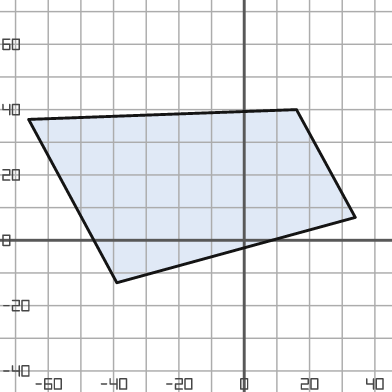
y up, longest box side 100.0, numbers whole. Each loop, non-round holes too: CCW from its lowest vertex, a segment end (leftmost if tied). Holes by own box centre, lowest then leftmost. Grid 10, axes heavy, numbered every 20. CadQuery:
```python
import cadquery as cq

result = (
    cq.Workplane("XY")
    .moveTo(-39.0, -13.0)
    .lineTo(34.0, 7.0)
    .lineTo(16.0, 40.0)
    .lineTo(-66.0, 37.0)
    .close()
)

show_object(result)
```